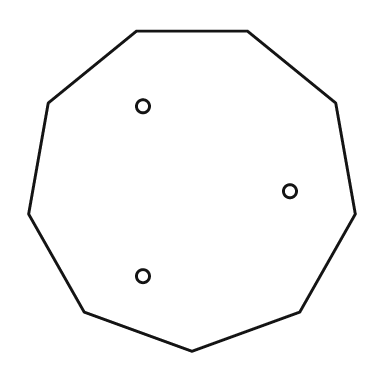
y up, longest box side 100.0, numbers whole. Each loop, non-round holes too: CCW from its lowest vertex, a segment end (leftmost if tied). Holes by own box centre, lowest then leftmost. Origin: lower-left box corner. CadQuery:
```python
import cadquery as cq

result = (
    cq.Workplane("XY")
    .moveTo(50.0, 0.0)
    .lineTo(83.0, 12.0)
    .lineTo(100.0, 42.0)
    .lineTo(94.0, 76.0)
    .lineTo(67.0, 98.0)
    .lineTo(33.0, 98.0)
    .lineTo(6.0, 76.0)
    .lineTo(0.0, 42.0)
    .lineTo(17.0, 12.0)
    .close()
    .moveTo(35.0, 23.0)
    .circle(2.0)
    .moveTo(80.0, 49.0)
    .circle(2.0)
    .moveTo(35.0, 75.0)
    .circle(2.0)
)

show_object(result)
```